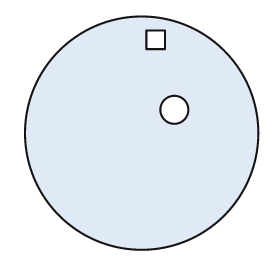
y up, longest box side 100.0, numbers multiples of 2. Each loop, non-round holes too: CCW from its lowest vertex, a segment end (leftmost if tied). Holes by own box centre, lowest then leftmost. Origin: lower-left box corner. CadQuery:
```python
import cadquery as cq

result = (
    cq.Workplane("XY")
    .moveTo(50.0, 50.0)
    .circle(50.0)
    .moveTo(64.0, 60.0)
    .circle(6.0)
    .moveTo(52.0, 86.0)
    .lineTo(60.0, 86.0)
    .lineTo(60.0, 94.0)
    .lineTo(52.0, 94.0)
    .close()
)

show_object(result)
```